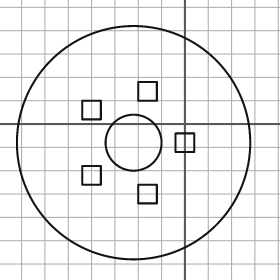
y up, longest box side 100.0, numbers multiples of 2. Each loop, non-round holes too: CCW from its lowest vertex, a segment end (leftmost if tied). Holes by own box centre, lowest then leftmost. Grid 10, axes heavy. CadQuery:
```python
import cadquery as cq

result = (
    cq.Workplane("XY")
    .moveTo(-22.0, -8.0)
    .circle(50.0)
    .moveTo(-20.0, -34.0)
    .lineTo(-12.0, -34.0)
    .lineTo(-12.0, -26.0)
    .lineTo(-20.0, -26.0)
    .close()
    .moveTo(-44.0, -26.0)
    .lineTo(-36.0, -26.0)
    .lineTo(-36.0, -18.0)
    .lineTo(-44.0, -18.0)
    .close()
    .moveTo(-22.0, -8.0)
    .circle(12.0)
    .moveTo(-4.0, -12.0)
    .lineTo(4.0, -12.0)
    .lineTo(4.0, -4.0)
    .lineTo(-4.0, -4.0)
    .close()
    .moveTo(-44.0, 2.0)
    .lineTo(-36.0, 2.0)
    .lineTo(-36.0, 10.0)
    .lineTo(-44.0, 10.0)
    .close()
    .moveTo(-20.0, 10.0)
    .lineTo(-12.0, 10.0)
    .lineTo(-12.0, 18.0)
    .lineTo(-20.0, 18.0)
    .close()
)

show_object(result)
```